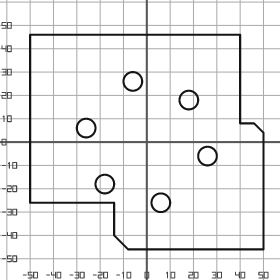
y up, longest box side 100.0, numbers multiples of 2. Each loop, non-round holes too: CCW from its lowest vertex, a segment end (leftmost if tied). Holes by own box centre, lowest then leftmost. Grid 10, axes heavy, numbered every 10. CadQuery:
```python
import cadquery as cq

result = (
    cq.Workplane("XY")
    .moveTo(-8.0, -46.0)
    .lineTo(50.0, -46.0)
    .lineTo(50.0, 4.0)
    .lineTo(46.0, 8.0)
    .lineTo(40.0, 8.0)
    .lineTo(40.0, 46.0)
    .lineTo(-50.0, 46.0)
    .lineTo(-50.0, -26.0)
    .lineTo(-14.0, -26.0)
    .lineTo(-14.0, -40.0)
    .close()
    .moveTo(6.0, -26.0)
    .circle(4.0)
    .moveTo(-18.0, -18.0)
    .circle(4.0)
    .moveTo(26.0, -6.0)
    .circle(4.0)
    .moveTo(-26.0, 6.0)
    .circle(4.0)
    .moveTo(18.0, 18.0)
    .circle(4.0)
    .moveTo(-6.0, 26.0)
    .circle(4.0)
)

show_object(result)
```